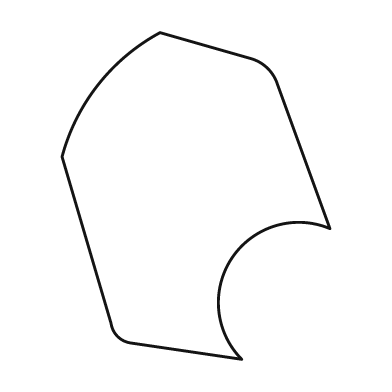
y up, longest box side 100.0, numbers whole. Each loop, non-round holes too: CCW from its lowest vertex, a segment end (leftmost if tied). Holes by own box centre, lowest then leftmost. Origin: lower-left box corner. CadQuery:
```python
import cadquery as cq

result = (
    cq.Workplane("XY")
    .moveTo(55.0, 0.0)
    .threePointArc((52.0, 31.0), (82.0, 40.0))
    .lineTo(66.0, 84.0)
    .threePointArc((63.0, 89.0), (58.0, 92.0))
    .lineTo(30.0, 100.0)
    .threePointArc((11.0, 84.0), (0.0, 62.0))
    .lineTo(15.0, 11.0)
    .threePointArc((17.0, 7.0), (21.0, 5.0))
    .close()
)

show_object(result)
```